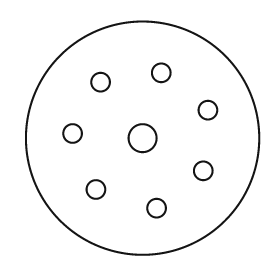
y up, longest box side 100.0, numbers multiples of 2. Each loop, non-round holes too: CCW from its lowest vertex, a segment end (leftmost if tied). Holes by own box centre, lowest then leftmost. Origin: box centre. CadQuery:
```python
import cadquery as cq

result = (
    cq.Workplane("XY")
    .moveTo(0.0, 0.0)
    .circle(50.0)
    .moveTo(6.0, -30.0)
    .circle(4.0)
    .moveTo(-20.0, -22.0)
    .circle(4.0)
    .moveTo(26.0, -14.0)
    .circle(4.0)
    .moveTo(0.0, 0.0)
    .circle(6.0)
    .moveTo(-30.0, 2.0)
    .circle(4.0)
    .moveTo(28.0, 12.0)
    .circle(4.0)
    .moveTo(-18.0, 24.0)
    .circle(4.0)
    .moveTo(8.0, 28.0)
    .circle(4.0)
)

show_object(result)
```